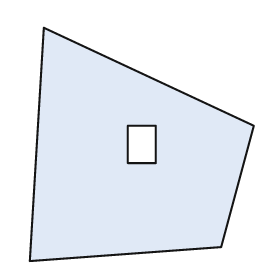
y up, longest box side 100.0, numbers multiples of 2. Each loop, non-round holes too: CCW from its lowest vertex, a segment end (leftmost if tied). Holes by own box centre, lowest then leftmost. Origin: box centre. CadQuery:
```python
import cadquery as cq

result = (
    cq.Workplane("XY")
    .moveTo(-48.0, -50.0)
    .lineTo(34.0, -44.0)
    .lineTo(48.0, 8.0)
    .lineTo(-42.0, 50.0)
    .close()
    .moveTo(-6.0, -8.0)
    .lineTo(6.0, -8.0)
    .lineTo(6.0, 8.0)
    .lineTo(-6.0, 8.0)
    .close()
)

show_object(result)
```